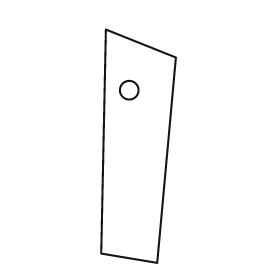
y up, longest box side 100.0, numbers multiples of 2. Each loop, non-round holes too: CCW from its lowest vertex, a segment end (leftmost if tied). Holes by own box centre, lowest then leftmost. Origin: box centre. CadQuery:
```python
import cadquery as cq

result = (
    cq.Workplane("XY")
    .moveTo(8.0, -50.0)
    .lineTo(16.0, 38.0)
    .lineTo(-14.0, 50.0)
    .lineTo(-16.0, -46.0)
    .close()
    .moveTo(-4.0, 24.0)
    .circle(4.0)
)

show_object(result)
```